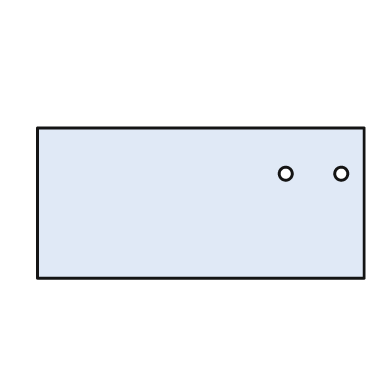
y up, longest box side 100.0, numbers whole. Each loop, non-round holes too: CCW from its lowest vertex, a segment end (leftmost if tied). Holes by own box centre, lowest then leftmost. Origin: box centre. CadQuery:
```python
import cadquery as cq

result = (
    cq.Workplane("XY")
    .moveTo(-50.0, -23.0)
    .lineTo(50.0, -23.0)
    .lineTo(50.0, 23.0)
    .lineTo(-50.0, 23.0)
    .close()
    .moveTo(26.0, 9.0)
    .circle(2.0)
    .moveTo(43.0, 9.0)
    .circle(2.0)
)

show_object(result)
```